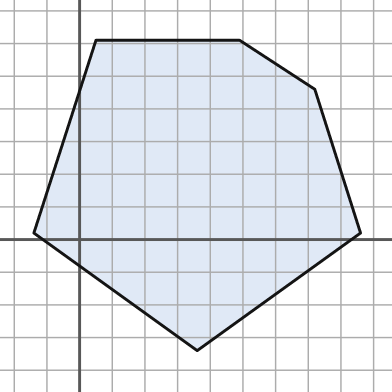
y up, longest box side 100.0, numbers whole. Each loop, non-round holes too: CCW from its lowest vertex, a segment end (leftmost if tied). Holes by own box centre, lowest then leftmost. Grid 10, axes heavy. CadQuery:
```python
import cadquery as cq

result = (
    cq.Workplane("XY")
    .moveTo(36.0, -34.0)
    .lineTo(86.0, 2.0)
    .lineTo(72.0, 46.0)
    .lineTo(49.0, 61.0)
    .lineTo(5.0, 61.0)
    .lineTo(-14.0, 2.0)
    .close()
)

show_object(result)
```